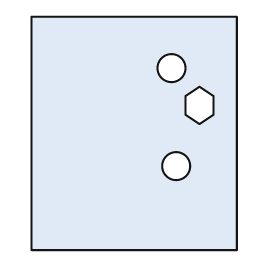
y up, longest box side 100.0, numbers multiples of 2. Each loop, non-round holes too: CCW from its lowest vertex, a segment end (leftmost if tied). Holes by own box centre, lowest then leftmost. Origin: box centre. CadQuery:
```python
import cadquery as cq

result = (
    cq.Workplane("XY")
    .moveTo(-44.0, -50.0)
    .lineTo(44.0, -50.0)
    .lineTo(44.0, 50.0)
    .lineTo(-44.0, 50.0)
    .close()
    .moveTo(18.0, -14.0)
    .circle(6.0)
    .moveTo(28.0, 4.0)
    .lineTo(34.0, 8.0)
    .lineTo(34.0, 16.0)
    .lineTo(28.0, 20.0)
    .lineTo(22.0, 16.0)
    .lineTo(22.0, 8.0)
    .close()
    .moveTo(16.0, 28.0)
    .circle(6.0)
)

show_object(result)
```